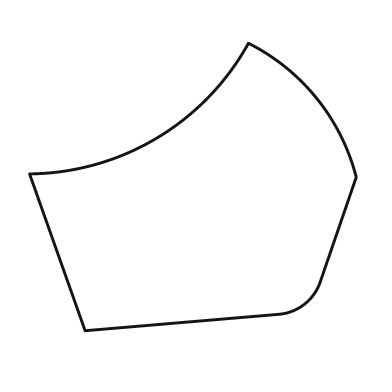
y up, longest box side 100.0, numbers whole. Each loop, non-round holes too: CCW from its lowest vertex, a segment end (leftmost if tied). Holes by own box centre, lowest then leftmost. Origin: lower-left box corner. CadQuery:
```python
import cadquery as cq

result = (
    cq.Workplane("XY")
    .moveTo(17.0, 0.0)
    .lineTo(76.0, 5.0)
    .threePointArc((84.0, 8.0), (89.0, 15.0))
    .lineTo(100.0, 47.0)
    .threePointArc((88.0, 71.0), (67.0, 88.0))
    .threePointArc((39.0, 59.0), (0.0, 48.0))
    .close()
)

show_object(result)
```